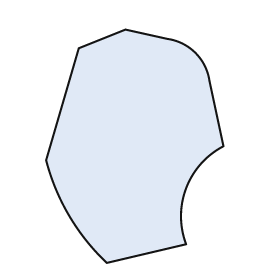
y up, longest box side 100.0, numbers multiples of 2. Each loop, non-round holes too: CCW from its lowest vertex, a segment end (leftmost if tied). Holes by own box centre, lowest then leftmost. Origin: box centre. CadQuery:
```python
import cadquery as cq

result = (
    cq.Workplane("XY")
    .moveTo(-12.0, -50.0)
    .lineTo(22.0, -42.0)
    .threePointArc((22.0, -18.0), (38.0, 0.0))
    .lineTo(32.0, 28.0)
    .threePointArc((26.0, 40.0), (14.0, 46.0))
    .lineTo(-4.0, 50.0)
    .lineTo(-24.0, 42.0)
    .lineTo(-38.0, -6.0)
    .threePointArc((-28.0, -30.0), (-12.0, -50.0))
    .close()
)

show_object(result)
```